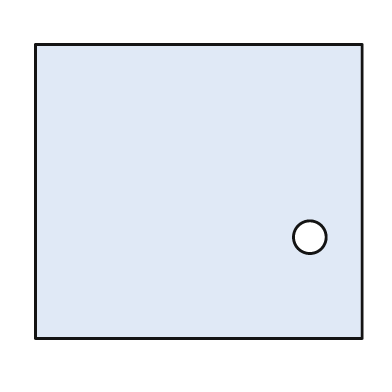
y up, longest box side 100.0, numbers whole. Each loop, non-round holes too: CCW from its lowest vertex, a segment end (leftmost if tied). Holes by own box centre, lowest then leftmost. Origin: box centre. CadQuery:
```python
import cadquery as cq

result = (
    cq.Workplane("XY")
    .moveTo(-50.0, -45.0)
    .lineTo(50.0, -45.0)
    .lineTo(50.0, 45.0)
    .lineTo(-50.0, 45.0)
    .close()
    .moveTo(34.0, -14.0)
    .circle(5.0)
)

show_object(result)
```